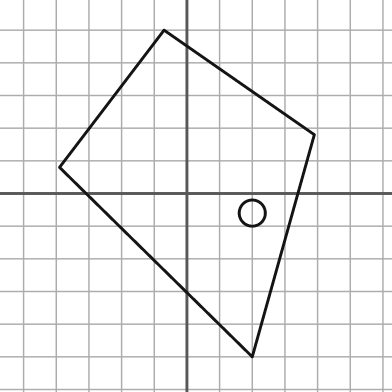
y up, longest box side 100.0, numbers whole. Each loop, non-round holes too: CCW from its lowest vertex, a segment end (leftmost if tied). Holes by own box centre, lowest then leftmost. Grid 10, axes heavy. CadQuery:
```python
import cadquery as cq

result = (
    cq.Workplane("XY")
    .moveTo(20.0, -50.0)
    .lineTo(39.0, 18.0)
    .lineTo(-7.0, 50.0)
    .lineTo(-39.0, 8.0)
    .close()
    .moveTo(20.0, -6.0)
    .circle(4.0)
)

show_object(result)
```